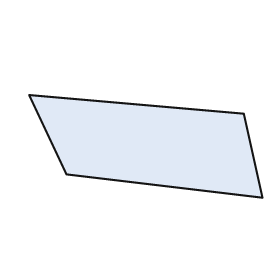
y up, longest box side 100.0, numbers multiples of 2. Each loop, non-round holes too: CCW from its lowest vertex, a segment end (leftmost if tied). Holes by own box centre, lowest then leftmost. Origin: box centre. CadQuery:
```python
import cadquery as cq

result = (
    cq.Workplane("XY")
    .moveTo(50.0, -22.0)
    .lineTo(42.0, 14.0)
    .lineTo(-50.0, 22.0)
    .lineTo(-34.0, -12.0)
    .close()
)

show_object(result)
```